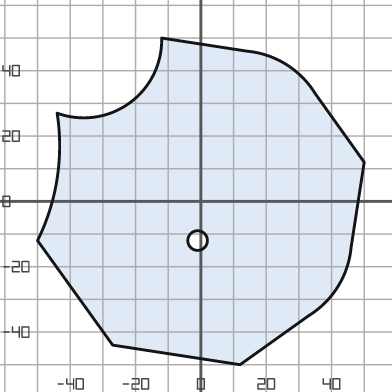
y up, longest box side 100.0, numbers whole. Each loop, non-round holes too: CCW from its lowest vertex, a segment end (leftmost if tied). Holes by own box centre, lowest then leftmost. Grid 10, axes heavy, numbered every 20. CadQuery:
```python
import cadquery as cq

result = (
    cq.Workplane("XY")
    .moveTo(12.0, -50.0)
    .lineTo(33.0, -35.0)
    .threePointArc((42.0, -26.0), (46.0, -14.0))
    .lineTo(50.0, 12.0)
    .lineTo(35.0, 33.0)
    .threePointArc((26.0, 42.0), (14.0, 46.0))
    .lineTo(-12.0, 50.0)
    .threePointArc((-22.0, 30.0), (-44.0, 27.0))
    .threePointArc((-44.0, 7.0), (-50.0, -12.0))
    .lineTo(-27.0, -44.0)
    .close()
    .moveTo(-1.0, -12.0)
    .circle(3.0)
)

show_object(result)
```